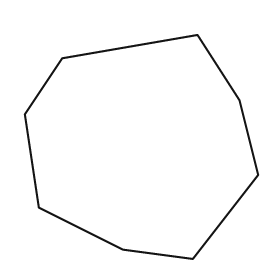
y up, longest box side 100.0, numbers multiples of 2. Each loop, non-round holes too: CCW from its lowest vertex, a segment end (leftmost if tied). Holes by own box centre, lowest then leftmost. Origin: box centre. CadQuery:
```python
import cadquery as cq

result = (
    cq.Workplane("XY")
    .moveTo(22.0, -48.0)
    .lineTo(50.0, -12.0)
    .lineTo(42.0, 20.0)
    .lineTo(24.0, 48.0)
    .lineTo(-34.0, 38.0)
    .lineTo(-50.0, 14.0)
    .lineTo(-44.0, -26.0)
    .lineTo(-8.0, -44.0)
    .close()
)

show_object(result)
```